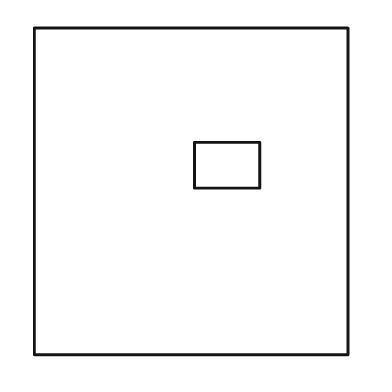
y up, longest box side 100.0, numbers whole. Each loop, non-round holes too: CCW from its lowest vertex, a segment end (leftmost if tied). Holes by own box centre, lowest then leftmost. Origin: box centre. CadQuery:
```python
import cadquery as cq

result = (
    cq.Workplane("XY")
    .moveTo(-48.0, -50.0)
    .lineTo(48.0, -50.0)
    .lineTo(48.0, 50.0)
    .lineTo(-48.0, 50.0)
    .close()
    .moveTo(1.0, 1.0)
    .lineTo(21.0, 1.0)
    .lineTo(21.0, 15.0)
    .lineTo(1.0, 15.0)
    .close()
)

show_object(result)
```